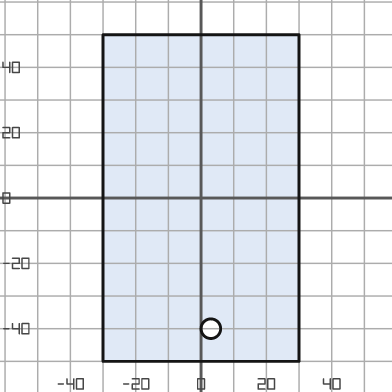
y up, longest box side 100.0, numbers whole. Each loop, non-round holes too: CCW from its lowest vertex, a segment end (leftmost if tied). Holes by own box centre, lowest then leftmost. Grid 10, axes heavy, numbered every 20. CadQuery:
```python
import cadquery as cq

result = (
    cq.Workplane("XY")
    .moveTo(-30.0, -50.0)
    .lineTo(30.0, -50.0)
    .lineTo(30.0, 50.0)
    .lineTo(-30.0, 50.0)
    .close()
    .moveTo(3.0, -40.0)
    .circle(3.0)
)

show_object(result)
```